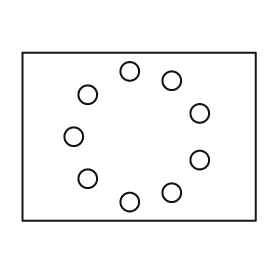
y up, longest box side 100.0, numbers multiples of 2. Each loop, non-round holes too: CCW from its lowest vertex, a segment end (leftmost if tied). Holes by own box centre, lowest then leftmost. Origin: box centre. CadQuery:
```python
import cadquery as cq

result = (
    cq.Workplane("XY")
    .moveTo(-50.0, -36.0)
    .lineTo(50.0, -36.0)
    .lineTo(50.0, 36.0)
    .lineTo(-50.0, 36.0)
    .close()
    .moveTo(-4.0, -28.0)
    .circle(4.0)
    .moveTo(14.0, -24.0)
    .circle(4.0)
    .moveTo(-22.0, -18.0)
    .circle(4.0)
    .moveTo(26.0, -10.0)
    .circle(4.0)
    .moveTo(-28.0, 0.0)
    .circle(4.0)
    .moveTo(26.0, 10.0)
    .circle(4.0)
    .moveTo(-22.0, 18.0)
    .circle(4.0)
    .moveTo(14.0, 24.0)
    .circle(4.0)
    .moveTo(-4.0, 28.0)
    .circle(4.0)
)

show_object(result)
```